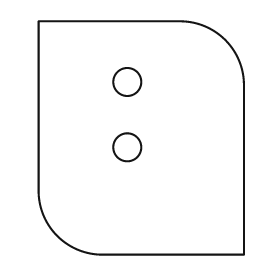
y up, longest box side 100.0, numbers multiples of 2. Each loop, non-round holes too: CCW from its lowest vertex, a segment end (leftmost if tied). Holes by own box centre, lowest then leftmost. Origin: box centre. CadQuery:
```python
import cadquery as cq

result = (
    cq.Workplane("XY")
    .moveTo(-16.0, -50.0)
    .lineTo(44.0, -50.0)
    .lineTo(44.0, 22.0)
    .threePointArc((36.0, 42.0), (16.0, 50.0))
    .lineTo(-44.0, 50.0)
    .lineTo(-44.0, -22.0)
    .threePointArc((-36.0, -42.0), (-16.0, -50.0))
    .close()
    .moveTo(-6.0, -4.0)
    .circle(6.0)
    .moveTo(-6.0, 24.0)
    .circle(6.0)
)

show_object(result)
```